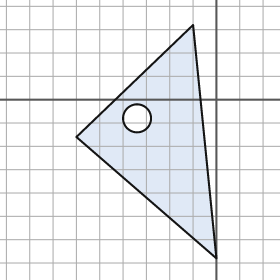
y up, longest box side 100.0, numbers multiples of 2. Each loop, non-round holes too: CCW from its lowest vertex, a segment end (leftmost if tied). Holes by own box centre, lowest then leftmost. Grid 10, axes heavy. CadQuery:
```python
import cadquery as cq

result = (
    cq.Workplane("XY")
    .moveTo(0.0, -68.0)
    .lineTo(-10.0, 32.0)
    .lineTo(-60.0, -16.0)
    .close()
    .moveTo(-34.0, -8.0)
    .circle(6.0)
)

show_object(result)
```